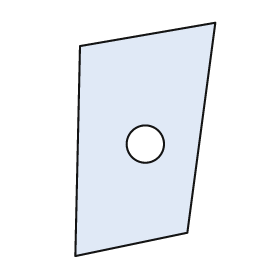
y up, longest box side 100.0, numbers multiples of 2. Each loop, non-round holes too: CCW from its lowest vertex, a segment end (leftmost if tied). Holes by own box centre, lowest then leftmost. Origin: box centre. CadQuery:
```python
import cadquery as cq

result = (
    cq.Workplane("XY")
    .moveTo(-30.0, -50.0)
    .lineTo(18.0, -40.0)
    .lineTo(30.0, 50.0)
    .lineTo(-28.0, 40.0)
    .close()
    .moveTo(0.0, -2.0)
    .circle(8.0)
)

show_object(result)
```